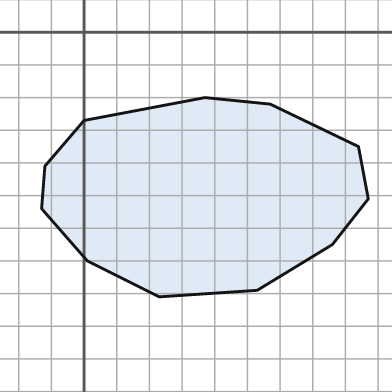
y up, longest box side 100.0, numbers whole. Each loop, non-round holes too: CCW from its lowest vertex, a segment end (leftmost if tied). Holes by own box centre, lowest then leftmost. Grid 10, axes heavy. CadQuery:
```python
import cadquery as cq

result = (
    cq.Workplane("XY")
    .moveTo(23.0, -81.0)
    .lineTo(53.0, -79.0)
    .lineTo(76.0, -65.0)
    .lineTo(87.0, -51.0)
    .lineTo(84.0, -35.0)
    .lineTo(57.0, -22.0)
    .lineTo(37.0, -20.0)
    .lineTo(0.0, -27.0)
    .lineTo(-12.0, -41.0)
    .lineTo(-13.0, -54.0)
    .lineTo(1.0, -70.0)
    .close()
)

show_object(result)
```